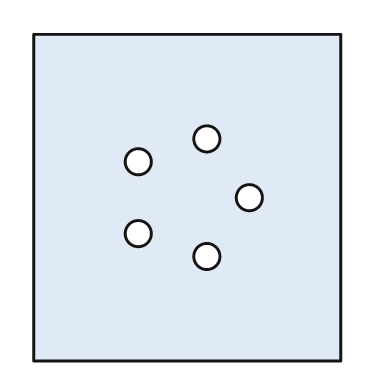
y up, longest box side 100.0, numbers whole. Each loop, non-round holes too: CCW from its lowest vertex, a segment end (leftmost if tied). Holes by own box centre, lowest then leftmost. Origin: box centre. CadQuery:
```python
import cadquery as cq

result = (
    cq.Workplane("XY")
    .moveTo(-47.0, -50.0)
    .lineTo(47.0, -50.0)
    .lineTo(47.0, 50.0)
    .lineTo(-47.0, 50.0)
    .close()
    .moveTo(6.0, -18.0)
    .circle(4.0)
    .moveTo(-15.0, -11.0)
    .circle(4.0)
    .moveTo(19.0, 0.0)
    .circle(4.0)
    .moveTo(-15.0, 11.0)
    .circle(4.0)
    .moveTo(6.0, 18.0)
    .circle(4.0)
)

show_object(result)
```